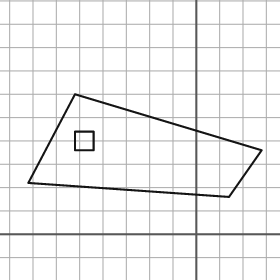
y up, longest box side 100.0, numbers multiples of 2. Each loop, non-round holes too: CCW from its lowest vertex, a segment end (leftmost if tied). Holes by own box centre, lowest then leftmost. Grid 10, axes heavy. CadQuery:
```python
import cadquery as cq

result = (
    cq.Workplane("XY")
    .moveTo(14.0, 16.0)
    .lineTo(28.0, 36.0)
    .lineTo(-52.0, 60.0)
    .lineTo(-72.0, 22.0)
    .close()
    .moveTo(-52.0, 36.0)
    .lineTo(-44.0, 36.0)
    .lineTo(-44.0, 44.0)
    .lineTo(-52.0, 44.0)
    .close()
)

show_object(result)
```